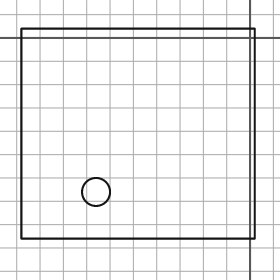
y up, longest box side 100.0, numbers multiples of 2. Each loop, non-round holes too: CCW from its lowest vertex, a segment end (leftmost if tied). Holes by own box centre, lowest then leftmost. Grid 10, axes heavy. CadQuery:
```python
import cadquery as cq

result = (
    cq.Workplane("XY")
    .moveTo(-98.0, -86.0)
    .lineTo(2.0, -86.0)
    .lineTo(2.0, 4.0)
    .lineTo(-98.0, 4.0)
    .close()
    .moveTo(-66.0, -66.0)
    .circle(6.0)
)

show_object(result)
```